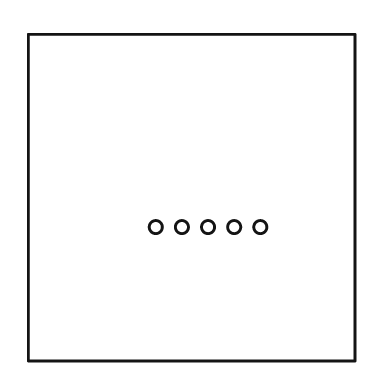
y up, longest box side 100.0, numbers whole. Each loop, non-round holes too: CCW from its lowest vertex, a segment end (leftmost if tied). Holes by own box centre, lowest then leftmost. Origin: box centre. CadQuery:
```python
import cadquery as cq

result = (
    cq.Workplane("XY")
    .moveTo(-50.0, -50.0)
    .lineTo(50.0, -50.0)
    .lineTo(50.0, 50.0)
    .lineTo(-50.0, 50.0)
    .close()
    .moveTo(-11.0, -9.0)
    .circle(2.0)
    .moveTo(-3.0, -9.0)
    .circle(2.0)
    .moveTo(5.0, -9.0)
    .circle(2.0)
    .moveTo(13.0, -9.0)
    .circle(2.0)
    .moveTo(21.0, -9.0)
    .circle(2.0)
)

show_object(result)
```